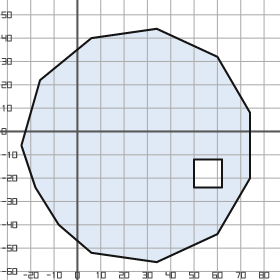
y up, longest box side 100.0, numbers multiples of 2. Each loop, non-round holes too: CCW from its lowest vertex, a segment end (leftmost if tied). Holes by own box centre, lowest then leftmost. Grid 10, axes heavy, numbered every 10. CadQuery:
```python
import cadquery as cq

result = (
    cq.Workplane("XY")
    .moveTo(34.0, -56.0)
    .lineTo(60.0, -44.0)
    .lineTo(74.0, -20.0)
    .lineTo(74.0, 8.0)
    .lineTo(60.0, 32.0)
    .lineTo(34.0, 44.0)
    .lineTo(6.0, 40.0)
    .lineTo(-16.0, 22.0)
    .lineTo(-24.0, -6.0)
    .lineTo(-18.0, -24.0)
    .lineTo(-8.0, -40.0)
    .lineTo(6.0, -52.0)
    .close()
    .moveTo(50.0, -24.0)
    .lineTo(62.0, -24.0)
    .lineTo(62.0, -12.0)
    .lineTo(50.0, -12.0)
    .close()
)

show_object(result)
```